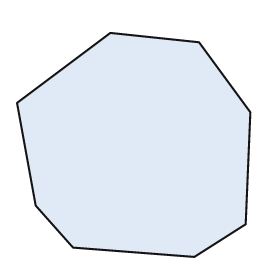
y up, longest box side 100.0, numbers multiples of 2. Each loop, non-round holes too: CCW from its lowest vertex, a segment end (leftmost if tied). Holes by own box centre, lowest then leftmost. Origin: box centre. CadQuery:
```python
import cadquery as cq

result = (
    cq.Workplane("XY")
    .moveTo(26.0, -48.0)
    .lineTo(48.0, -34.0)
    .lineTo(50.0, 14.0)
    .lineTo(28.0, 44.0)
    .lineTo(-10.0, 48.0)
    .lineTo(-50.0, 18.0)
    .lineTo(-42.0, -26.0)
    .lineTo(-26.0, -44.0)
    .close()
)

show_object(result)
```